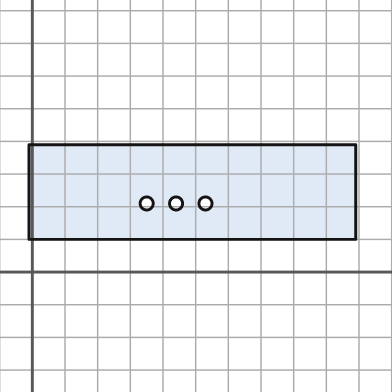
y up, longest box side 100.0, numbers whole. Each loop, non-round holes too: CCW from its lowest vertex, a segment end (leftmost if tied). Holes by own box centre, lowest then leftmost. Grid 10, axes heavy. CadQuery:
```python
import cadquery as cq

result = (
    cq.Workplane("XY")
    .moveTo(-1.0, 10.0)
    .lineTo(99.0, 10.0)
    .lineTo(99.0, 39.0)
    .lineTo(-1.0, 39.0)
    .close()
    .moveTo(35.0, 21.0)
    .circle(2.0)
    .moveTo(44.0, 21.0)
    .circle(2.0)
    .moveTo(53.0, 21.0)
    .circle(2.0)
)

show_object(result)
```